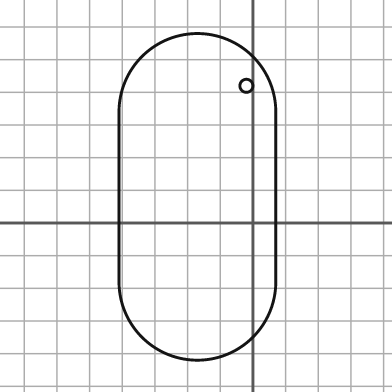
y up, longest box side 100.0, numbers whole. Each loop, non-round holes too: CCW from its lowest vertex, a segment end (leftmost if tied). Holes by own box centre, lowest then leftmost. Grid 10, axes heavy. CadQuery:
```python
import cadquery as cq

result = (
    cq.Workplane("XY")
    .moveTo(-41.0, -18.0)
    .threePointArc((-17.0, -42.0), (7.0, -18.0))
    .lineTo(7.0, 34.0)
    .threePointArc((-17.0, 58.0), (-41.0, 34.0))
    .close()
    .moveTo(-2.0, 42.0)
    .circle(2.0)
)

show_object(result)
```